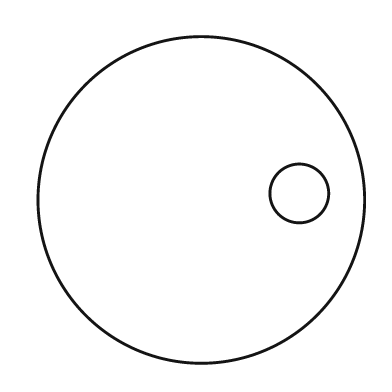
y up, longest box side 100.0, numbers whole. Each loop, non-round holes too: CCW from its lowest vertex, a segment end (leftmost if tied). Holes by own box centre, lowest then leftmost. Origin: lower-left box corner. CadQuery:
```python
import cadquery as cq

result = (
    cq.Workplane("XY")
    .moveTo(50.0, 50.0)
    .circle(50.0)
    .moveTo(80.0, 52.0)
    .circle(9.0)
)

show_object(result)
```